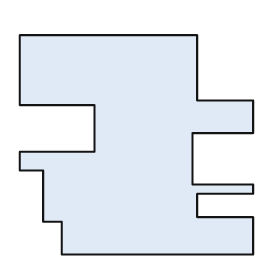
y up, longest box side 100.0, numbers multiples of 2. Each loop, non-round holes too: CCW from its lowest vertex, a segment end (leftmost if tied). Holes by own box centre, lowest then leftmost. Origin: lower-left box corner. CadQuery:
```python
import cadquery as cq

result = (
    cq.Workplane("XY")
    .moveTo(18.0, 0.0)
    .lineTo(100.0, 0.0)
    .lineTo(100.0, 16.0)
    .lineTo(76.0, 16.0)
    .lineTo(76.0, 26.0)
    .lineTo(100.0, 26.0)
    .lineTo(100.0, 30.0)
    .lineTo(74.0, 30.0)
    .lineTo(74.0, 52.0)
    .lineTo(100.0, 52.0)
    .lineTo(100.0, 66.0)
    .lineTo(76.0, 66.0)
    .lineTo(76.0, 94.0)
    .lineTo(0.0, 94.0)
    .lineTo(0.0, 64.0)
    .lineTo(32.0, 64.0)
    .lineTo(32.0, 44.0)
    .lineTo(0.0, 44.0)
    .lineTo(0.0, 36.0)
    .lineTo(10.0, 36.0)
    .lineTo(10.0, 14.0)
    .lineTo(18.0, 14.0)
    .close()
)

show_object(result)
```